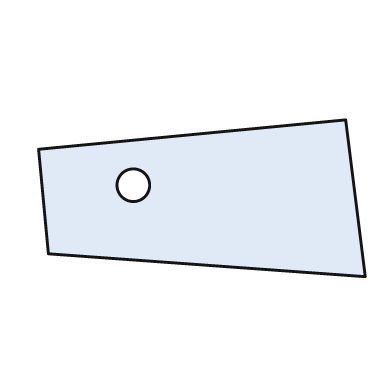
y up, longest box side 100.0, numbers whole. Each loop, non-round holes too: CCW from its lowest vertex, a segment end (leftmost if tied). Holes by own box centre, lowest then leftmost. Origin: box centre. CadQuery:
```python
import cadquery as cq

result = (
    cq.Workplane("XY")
    .moveTo(50.0, -24.0)
    .lineTo(44.0, 24.0)
    .lineTo(-50.0, 15.0)
    .lineTo(-47.0, -17.0)
    .close()
    .moveTo(-21.0, 4.0)
    .circle(5.0)
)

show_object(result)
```